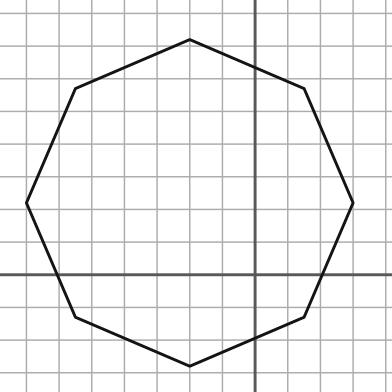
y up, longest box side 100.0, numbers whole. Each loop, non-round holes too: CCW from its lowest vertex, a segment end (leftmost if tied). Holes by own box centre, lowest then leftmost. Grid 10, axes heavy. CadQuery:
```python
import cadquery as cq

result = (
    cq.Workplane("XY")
    .moveTo(-20.0, -28.0)
    .lineTo(15.0, -13.0)
    .lineTo(30.0, 22.0)
    .lineTo(15.0, 57.0)
    .lineTo(-20.0, 72.0)
    .lineTo(-55.0, 57.0)
    .lineTo(-70.0, 22.0)
    .lineTo(-55.0, -13.0)
    .close()
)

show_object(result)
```